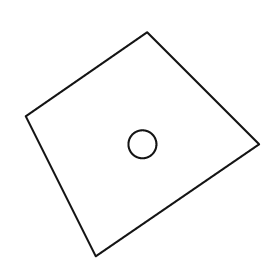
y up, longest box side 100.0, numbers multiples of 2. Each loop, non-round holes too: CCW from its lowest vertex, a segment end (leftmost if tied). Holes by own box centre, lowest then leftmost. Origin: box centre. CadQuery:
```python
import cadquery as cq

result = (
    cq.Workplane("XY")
    .moveTo(-20.0, -48.0)
    .lineTo(50.0, 0.0)
    .lineTo(2.0, 48.0)
    .lineTo(-50.0, 12.0)
    .close()
    .moveTo(0.0, 0.0)
    .circle(6.0)
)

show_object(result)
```